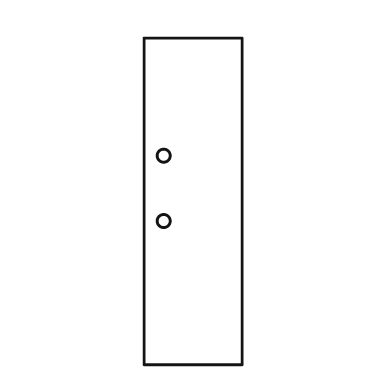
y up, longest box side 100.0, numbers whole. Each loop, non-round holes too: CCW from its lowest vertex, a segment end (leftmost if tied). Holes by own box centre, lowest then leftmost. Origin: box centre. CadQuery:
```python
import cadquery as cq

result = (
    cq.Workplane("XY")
    .moveTo(-15.0, -50.0)
    .lineTo(15.0, -50.0)
    .lineTo(15.0, 50.0)
    .lineTo(-15.0, 50.0)
    .close()
    .moveTo(-9.0, -6.0)
    .circle(2.0)
    .moveTo(-9.0, 14.0)
    .circle(2.0)
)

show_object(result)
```